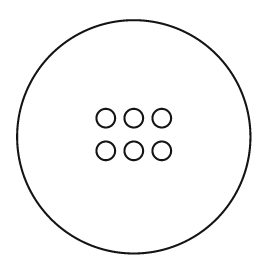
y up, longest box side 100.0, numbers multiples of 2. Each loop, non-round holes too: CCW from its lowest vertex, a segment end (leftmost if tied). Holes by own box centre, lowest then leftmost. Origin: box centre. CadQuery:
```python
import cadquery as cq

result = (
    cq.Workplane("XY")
    .moveTo(0.0, 0.0)
    .circle(50.0)
    .moveTo(-12.0, -6.0)
    .circle(4.0)
    .moveTo(0.0, -6.0)
    .circle(4.0)
    .moveTo(12.0, -6.0)
    .circle(4.0)
    .moveTo(-12.0, 8.0)
    .circle(4.0)
    .moveTo(0.0, 8.0)
    .circle(4.0)
    .moveTo(12.0, 8.0)
    .circle(4.0)
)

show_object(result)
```